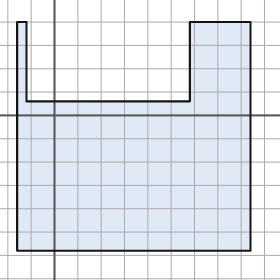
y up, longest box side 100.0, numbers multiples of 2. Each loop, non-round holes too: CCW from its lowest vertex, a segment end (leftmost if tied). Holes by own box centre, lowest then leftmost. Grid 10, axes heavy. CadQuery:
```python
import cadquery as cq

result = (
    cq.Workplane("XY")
    .moveTo(-16.0, -58.0)
    .lineTo(84.0, -58.0)
    .lineTo(84.0, 40.0)
    .lineTo(58.0, 40.0)
    .lineTo(58.0, 6.0)
    .lineTo(-12.0, 6.0)
    .lineTo(-12.0, 40.0)
    .lineTo(-16.0, 40.0)
    .close()
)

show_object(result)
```